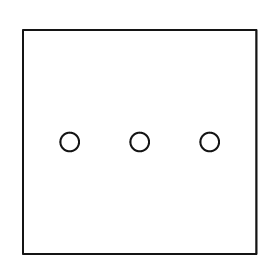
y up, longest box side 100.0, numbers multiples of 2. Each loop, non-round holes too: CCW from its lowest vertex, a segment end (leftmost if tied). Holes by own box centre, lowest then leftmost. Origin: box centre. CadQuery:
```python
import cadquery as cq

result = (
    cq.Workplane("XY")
    .moveTo(-50.0, -48.0)
    .lineTo(50.0, -48.0)
    .lineTo(50.0, 48.0)
    .lineTo(-50.0, 48.0)
    .close()
    .moveTo(-30.0, 0.0)
    .circle(4.0)
    .moveTo(0.0, 0.0)
    .circle(4.0)
    .moveTo(30.0, 0.0)
    .circle(4.0)
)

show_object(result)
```